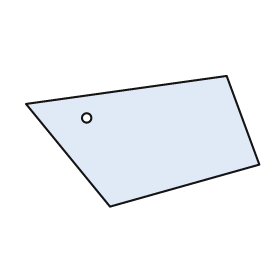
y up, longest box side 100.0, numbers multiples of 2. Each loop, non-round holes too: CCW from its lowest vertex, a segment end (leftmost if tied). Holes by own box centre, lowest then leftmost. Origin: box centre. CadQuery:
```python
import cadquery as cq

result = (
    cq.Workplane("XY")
    .moveTo(-14.0, -28.0)
    .lineTo(50.0, -10.0)
    .lineTo(36.0, 28.0)
    .lineTo(-50.0, 16.0)
    .close()
    .moveTo(-24.0, 10.0)
    .circle(2.0)
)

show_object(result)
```